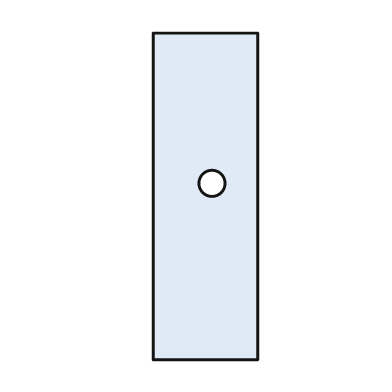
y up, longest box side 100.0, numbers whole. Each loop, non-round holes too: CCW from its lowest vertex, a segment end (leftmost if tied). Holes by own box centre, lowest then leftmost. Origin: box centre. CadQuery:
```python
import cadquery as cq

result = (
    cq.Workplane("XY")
    .moveTo(-16.0, -50.0)
    .lineTo(16.0, -50.0)
    .lineTo(16.0, 50.0)
    .lineTo(-16.0, 50.0)
    .close()
    .moveTo(2.0, 4.0)
    .circle(4.0)
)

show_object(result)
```